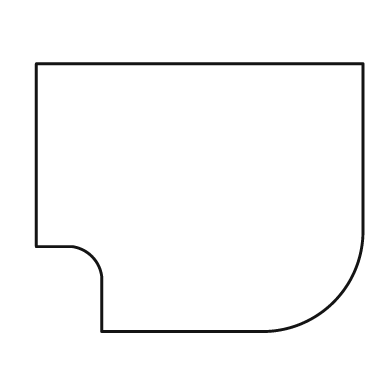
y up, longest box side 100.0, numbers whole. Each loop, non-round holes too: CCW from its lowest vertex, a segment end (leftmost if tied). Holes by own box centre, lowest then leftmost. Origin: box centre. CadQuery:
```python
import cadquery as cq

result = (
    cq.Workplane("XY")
    .moveTo(-30.0, -41.0)
    .lineTo(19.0, -41.0)
    .threePointArc((41.0, -32.0), (50.0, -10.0))
    .lineTo(50.0, 41.0)
    .lineTo(-50.0, 41.0)
    .lineTo(-50.0, -15.0)
    .lineTo(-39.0, -15.0)
    .threePointArc((-33.0, -18.0), (-30.0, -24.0))
    .close()
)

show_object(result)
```